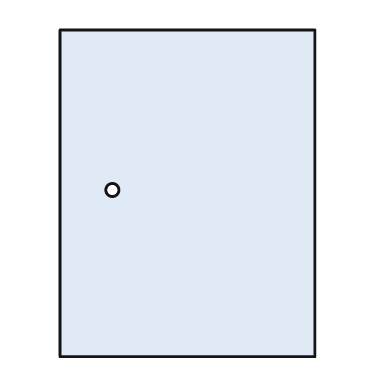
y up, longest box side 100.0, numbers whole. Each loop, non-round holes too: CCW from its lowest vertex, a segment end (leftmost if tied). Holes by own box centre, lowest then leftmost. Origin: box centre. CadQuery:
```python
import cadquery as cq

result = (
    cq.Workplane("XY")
    .moveTo(-39.0, -50.0)
    .lineTo(39.0, -50.0)
    .lineTo(39.0, 50.0)
    .lineTo(-39.0, 50.0)
    .close()
    .moveTo(-23.0, 1.0)
    .circle(2.0)
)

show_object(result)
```